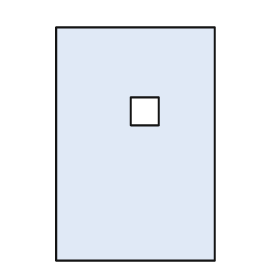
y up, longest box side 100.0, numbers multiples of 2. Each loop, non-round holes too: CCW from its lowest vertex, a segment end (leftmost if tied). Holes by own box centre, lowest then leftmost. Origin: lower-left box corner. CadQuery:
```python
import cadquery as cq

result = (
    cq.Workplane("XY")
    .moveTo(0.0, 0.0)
    .lineTo(68.0, 0.0)
    .lineTo(68.0, 100.0)
    .lineTo(0.0, 100.0)
    .close()
    .moveTo(32.0, 58.0)
    .lineTo(44.0, 58.0)
    .lineTo(44.0, 70.0)
    .lineTo(32.0, 70.0)
    .close()
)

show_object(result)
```